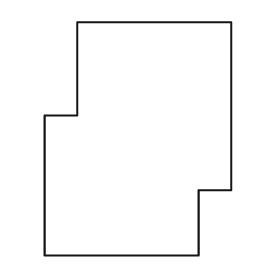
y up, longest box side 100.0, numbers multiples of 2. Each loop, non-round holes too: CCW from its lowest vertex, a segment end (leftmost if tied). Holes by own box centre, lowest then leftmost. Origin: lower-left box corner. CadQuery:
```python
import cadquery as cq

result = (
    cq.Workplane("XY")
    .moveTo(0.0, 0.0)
    .lineTo(66.0, 0.0)
    .lineTo(66.0, 28.0)
    .lineTo(80.0, 28.0)
    .lineTo(80.0, 100.0)
    .lineTo(14.0, 100.0)
    .lineTo(14.0, 60.0)
    .lineTo(0.0, 60.0)
    .close()
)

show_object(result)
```